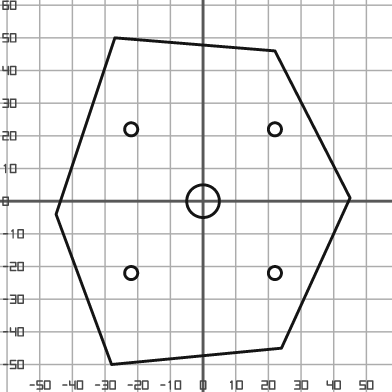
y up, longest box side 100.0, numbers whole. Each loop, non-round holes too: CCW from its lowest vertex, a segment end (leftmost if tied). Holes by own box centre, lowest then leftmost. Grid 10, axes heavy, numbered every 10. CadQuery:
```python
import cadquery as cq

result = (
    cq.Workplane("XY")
    .moveTo(-28.0, -50.0)
    .lineTo(24.0, -45.0)
    .lineTo(45.0, 1.0)
    .lineTo(22.0, 46.0)
    .lineTo(-27.0, 50.0)
    .lineTo(-45.0, -4.0)
    .close()
    .moveTo(-22.0, -22.0)
    .circle(2.0)
    .moveTo(22.0, -22.0)
    .circle(2.0)
    .moveTo(0.0, 0.0)
    .circle(5.0)
    .moveTo(-22.0, 22.0)
    .circle(2.0)
    .moveTo(22.0, 22.0)
    .circle(2.0)
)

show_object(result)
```